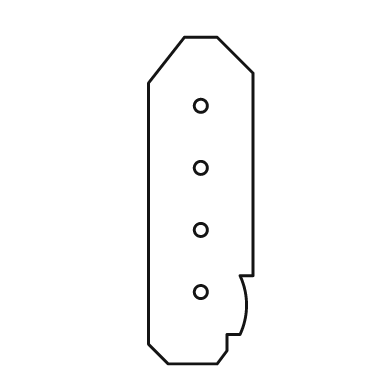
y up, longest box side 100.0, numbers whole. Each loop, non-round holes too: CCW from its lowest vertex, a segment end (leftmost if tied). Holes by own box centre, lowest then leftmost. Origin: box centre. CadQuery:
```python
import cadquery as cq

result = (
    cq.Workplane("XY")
    .moveTo(-10.0, -50.0)
    .lineTo(5.0, -50.0)
    .lineTo(8.0, -46.0)
    .lineTo(8.0, -41.0)
    .lineTo(12.0, -41.0)
    .threePointArc((14.0, -32.0), (12.0, -23.0))
    .lineTo(16.0, -23.0)
    .lineTo(16.0, 39.0)
    .lineTo(5.0, 50.0)
    .lineTo(-5.0, 50.0)
    .lineTo(-16.0, 36.0)
    .lineTo(-16.0, -44.0)
    .close()
    .moveTo(0.0, -28.0)
    .circle(2.0)
    .moveTo(0.0, -9.0)
    .circle(2.0)
    .moveTo(0.0, 10.0)
    .circle(2.0)
    .moveTo(0.0, 29.0)
    .circle(2.0)
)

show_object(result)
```